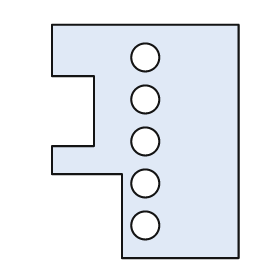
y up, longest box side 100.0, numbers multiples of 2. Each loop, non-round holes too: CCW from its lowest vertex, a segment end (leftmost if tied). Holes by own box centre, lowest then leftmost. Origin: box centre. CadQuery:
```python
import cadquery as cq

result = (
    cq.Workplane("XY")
    .moveTo(-10.0, -50.0)
    .lineTo(40.0, -50.0)
    .lineTo(40.0, 50.0)
    .lineTo(-40.0, 50.0)
    .lineTo(-40.0, 28.0)
    .lineTo(-22.0, 28.0)
    .lineTo(-22.0, -2.0)
    .lineTo(-40.0, -2.0)
    .lineTo(-40.0, -14.0)
    .lineTo(-10.0, -14.0)
    .close()
    .moveTo(0.0, -36.0)
    .circle(6.0)
    .moveTo(0.0, -18.0)
    .circle(6.0)
    .moveTo(0.0, 0.0)
    .circle(6.0)
    .moveTo(0.0, 18.0)
    .circle(6.0)
    .moveTo(0.0, 36.0)
    .circle(6.0)
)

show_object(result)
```